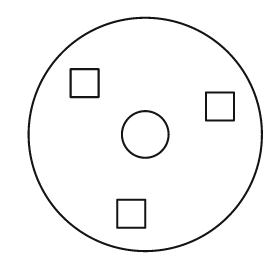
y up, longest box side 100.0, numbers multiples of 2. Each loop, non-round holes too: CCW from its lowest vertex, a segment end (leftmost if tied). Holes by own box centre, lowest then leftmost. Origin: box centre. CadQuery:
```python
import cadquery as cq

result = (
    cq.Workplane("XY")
    .moveTo(0.0, 0.0)
    .circle(50.0)
    .moveTo(-12.0, -40.0)
    .lineTo(0.0, -40.0)
    .lineTo(0.0, -28.0)
    .lineTo(-12.0, -28.0)
    .close()
    .moveTo(0.0, 0.0)
    .circle(10.0)
    .moveTo(26.0, 6.0)
    .lineTo(38.0, 6.0)
    .lineTo(38.0, 18.0)
    .lineTo(26.0, 18.0)
    .close()
    .moveTo(-32.0, 16.0)
    .lineTo(-20.0, 16.0)
    .lineTo(-20.0, 28.0)
    .lineTo(-32.0, 28.0)
    .close()
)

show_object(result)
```